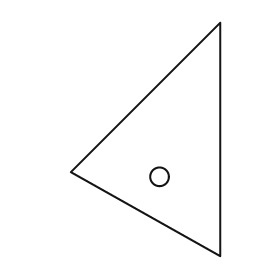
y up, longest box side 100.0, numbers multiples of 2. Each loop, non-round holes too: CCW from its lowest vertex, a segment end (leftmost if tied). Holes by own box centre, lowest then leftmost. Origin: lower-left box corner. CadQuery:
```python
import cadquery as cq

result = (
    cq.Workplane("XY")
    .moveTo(64.0, 0.0)
    .lineTo(64.0, 100.0)
    .lineTo(0.0, 36.0)
    .close()
    .moveTo(38.0, 34.0)
    .circle(4.0)
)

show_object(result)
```